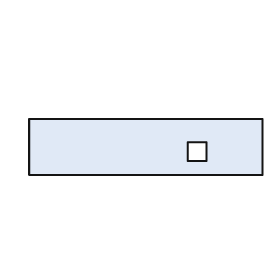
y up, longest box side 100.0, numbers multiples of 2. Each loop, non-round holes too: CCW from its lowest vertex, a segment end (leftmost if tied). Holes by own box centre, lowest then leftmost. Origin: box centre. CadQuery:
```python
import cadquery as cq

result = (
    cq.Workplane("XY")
    .moveTo(-50.0, -12.0)
    .lineTo(50.0, -12.0)
    .lineTo(50.0, 12.0)
    .lineTo(-50.0, 12.0)
    .close()
    .moveTo(18.0, -6.0)
    .lineTo(26.0, -6.0)
    .lineTo(26.0, 2.0)
    .lineTo(18.0, 2.0)
    .close()
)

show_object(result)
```